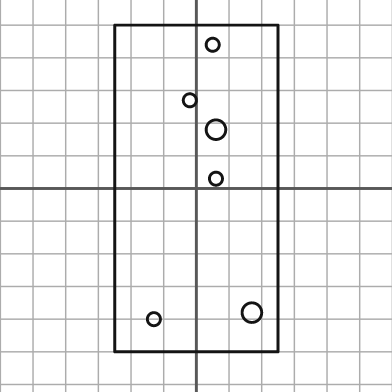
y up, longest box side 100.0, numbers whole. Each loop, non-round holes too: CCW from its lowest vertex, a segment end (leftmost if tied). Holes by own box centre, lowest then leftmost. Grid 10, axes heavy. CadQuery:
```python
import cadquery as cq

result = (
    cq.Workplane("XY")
    .moveTo(-25.0, -50.0)
    .lineTo(25.0, -50.0)
    .lineTo(25.0, 50.0)
    .lineTo(-25.0, 50.0)
    .close()
    .moveTo(-13.0, -40.0)
    .circle(2.0)
    .moveTo(17.0, -38.0)
    .circle(3.0)
    .moveTo(6.0, 3.0)
    .circle(2.0)
    .moveTo(6.0, 18.0)
    .circle(3.0)
    .moveTo(-2.0, 27.0)
    .circle(2.0)
    .moveTo(5.0, 44.0)
    .circle(2.0)
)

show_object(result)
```